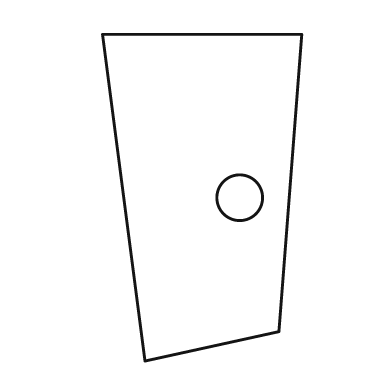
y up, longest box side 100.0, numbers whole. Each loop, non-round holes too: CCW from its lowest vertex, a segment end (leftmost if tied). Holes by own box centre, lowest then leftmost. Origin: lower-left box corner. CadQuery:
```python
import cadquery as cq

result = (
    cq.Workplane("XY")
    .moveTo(13.0, 0.0)
    .lineTo(54.0, 9.0)
    .lineTo(61.0, 100.0)
    .lineTo(0.0, 100.0)
    .close()
    .moveTo(42.0, 50.0)
    .circle(7.0)
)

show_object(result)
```